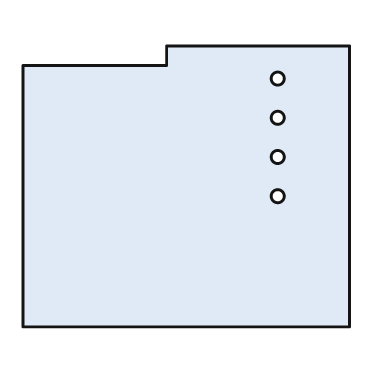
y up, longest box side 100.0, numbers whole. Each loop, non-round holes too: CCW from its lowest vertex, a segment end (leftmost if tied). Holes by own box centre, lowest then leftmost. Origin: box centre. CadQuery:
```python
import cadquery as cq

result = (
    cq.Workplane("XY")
    .moveTo(-50.0, -43.0)
    .lineTo(50.0, -43.0)
    .lineTo(50.0, 43.0)
    .lineTo(-6.0, 43.0)
    .lineTo(-6.0, 37.0)
    .lineTo(-50.0, 37.0)
    .close()
    .moveTo(28.0, -3.0)
    .circle(2.0)
    .moveTo(28.0, 9.0)
    .circle(2.0)
    .moveTo(28.0, 21.0)
    .circle(2.0)
    .moveTo(28.0, 33.0)
    .circle(2.0)
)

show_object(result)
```